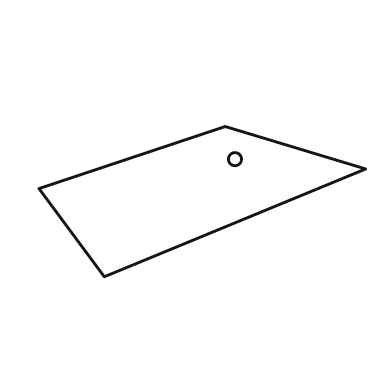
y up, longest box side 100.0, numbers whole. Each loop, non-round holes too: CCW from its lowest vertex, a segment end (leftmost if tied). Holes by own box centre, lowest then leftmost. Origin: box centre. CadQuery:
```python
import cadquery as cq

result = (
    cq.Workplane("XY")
    .moveTo(-30.0, -23.0)
    .lineTo(50.0, 10.0)
    .lineTo(7.0, 23.0)
    .lineTo(-50.0, 4.0)
    .close()
    .moveTo(10.0, 13.0)
    .circle(2.0)
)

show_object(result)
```